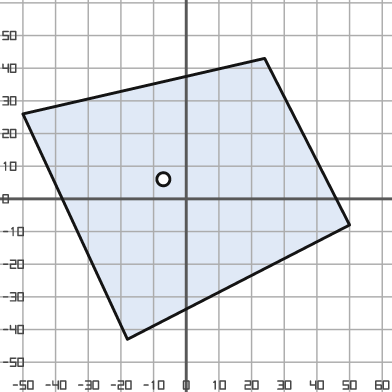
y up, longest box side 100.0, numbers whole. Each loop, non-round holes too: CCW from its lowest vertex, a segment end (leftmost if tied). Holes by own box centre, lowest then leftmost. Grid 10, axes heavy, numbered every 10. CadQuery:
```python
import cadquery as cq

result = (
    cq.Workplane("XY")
    .moveTo(-18.0, -43.0)
    .lineTo(50.0, -8.0)
    .lineTo(24.0, 43.0)
    .lineTo(-50.0, 26.0)
    .close()
    .moveTo(-7.0, 6.0)
    .circle(2.0)
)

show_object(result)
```